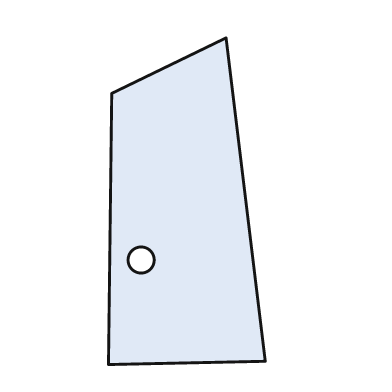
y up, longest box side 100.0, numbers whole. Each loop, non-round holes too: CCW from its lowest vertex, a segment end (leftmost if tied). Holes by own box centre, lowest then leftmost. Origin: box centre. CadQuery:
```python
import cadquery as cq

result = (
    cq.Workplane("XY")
    .moveTo(-24.0, -50.0)
    .lineTo(24.0, -49.0)
    .lineTo(12.0, 50.0)
    .lineTo(-23.0, 33.0)
    .close()
    .moveTo(-14.0, -18.0)
    .circle(4.0)
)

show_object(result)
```